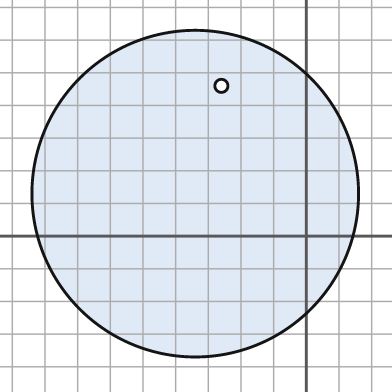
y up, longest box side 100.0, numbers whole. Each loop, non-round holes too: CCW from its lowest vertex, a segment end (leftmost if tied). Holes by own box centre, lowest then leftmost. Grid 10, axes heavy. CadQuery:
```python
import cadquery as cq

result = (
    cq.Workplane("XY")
    .moveTo(-34.0, 13.0)
    .circle(50.0)
    .moveTo(-26.0, 46.0)
    .circle(2.0)
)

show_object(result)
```